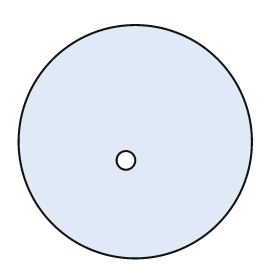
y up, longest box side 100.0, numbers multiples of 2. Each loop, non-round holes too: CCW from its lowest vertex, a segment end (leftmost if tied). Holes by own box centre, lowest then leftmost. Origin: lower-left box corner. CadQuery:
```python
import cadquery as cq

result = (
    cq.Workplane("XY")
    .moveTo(50.0, 50.0)
    .circle(50.0)
    .moveTo(46.0, 42.0)
    .circle(4.0)
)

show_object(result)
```